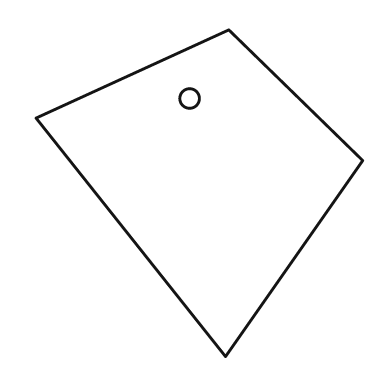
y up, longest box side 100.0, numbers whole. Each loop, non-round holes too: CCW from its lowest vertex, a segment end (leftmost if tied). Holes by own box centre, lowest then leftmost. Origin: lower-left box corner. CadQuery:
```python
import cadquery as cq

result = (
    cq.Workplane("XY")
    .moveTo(58.0, 0.0)
    .lineTo(100.0, 60.0)
    .lineTo(59.0, 100.0)
    .lineTo(0.0, 73.0)
    .close()
    .moveTo(47.0, 79.0)
    .circle(3.0)
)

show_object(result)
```